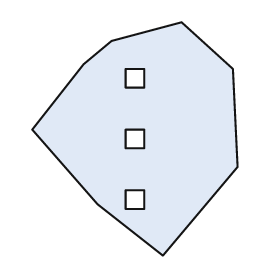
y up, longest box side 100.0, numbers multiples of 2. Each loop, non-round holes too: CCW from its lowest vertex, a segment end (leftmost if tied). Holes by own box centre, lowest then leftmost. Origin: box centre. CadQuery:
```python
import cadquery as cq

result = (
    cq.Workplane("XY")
    .moveTo(12.0, -50.0)
    .lineTo(44.0, -12.0)
    .lineTo(42.0, 30.0)
    .lineTo(20.0, 50.0)
    .lineTo(-10.0, 42.0)
    .lineTo(-22.0, 32.0)
    .lineTo(-44.0, 4.0)
    .lineTo(-16.0, -28.0)
    .close()
    .moveTo(-4.0, -30.0)
    .lineTo(4.0, -30.0)
    .lineTo(4.0, -22.0)
    .lineTo(-4.0, -22.0)
    .close()
    .moveTo(-4.0, -4.0)
    .lineTo(4.0, -4.0)
    .lineTo(4.0, 4.0)
    .lineTo(-4.0, 4.0)
    .close()
    .moveTo(-4.0, 22.0)
    .lineTo(4.0, 22.0)
    .lineTo(4.0, 30.0)
    .lineTo(-4.0, 30.0)
    .close()
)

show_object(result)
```